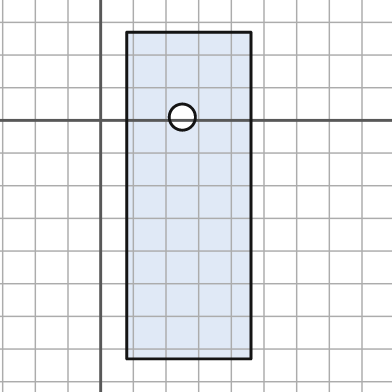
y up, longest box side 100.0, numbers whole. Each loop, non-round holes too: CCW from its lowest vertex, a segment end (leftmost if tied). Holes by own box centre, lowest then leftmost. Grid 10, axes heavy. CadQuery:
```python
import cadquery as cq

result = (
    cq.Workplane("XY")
    .moveTo(8.0, -73.0)
    .lineTo(46.0, -73.0)
    .lineTo(46.0, 27.0)
    .lineTo(8.0, 27.0)
    .close()
    .moveTo(25.0, 1.0)
    .circle(4.0)
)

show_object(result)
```